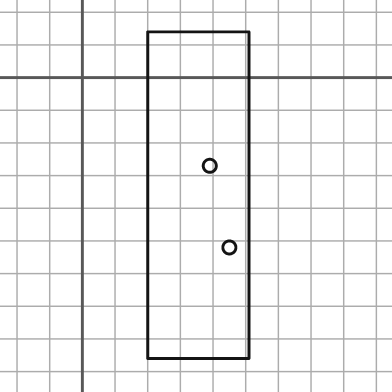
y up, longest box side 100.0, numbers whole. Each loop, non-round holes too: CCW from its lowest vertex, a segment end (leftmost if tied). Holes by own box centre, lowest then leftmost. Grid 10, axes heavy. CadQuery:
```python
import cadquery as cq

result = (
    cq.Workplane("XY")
    .moveTo(20.0, -86.0)
    .lineTo(51.0, -86.0)
    .lineTo(51.0, 14.0)
    .lineTo(20.0, 14.0)
    .close()
    .moveTo(45.0, -52.0)
    .circle(2.0)
    .moveTo(39.0, -27.0)
    .circle(2.0)
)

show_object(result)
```